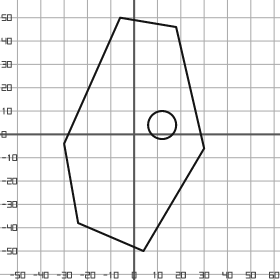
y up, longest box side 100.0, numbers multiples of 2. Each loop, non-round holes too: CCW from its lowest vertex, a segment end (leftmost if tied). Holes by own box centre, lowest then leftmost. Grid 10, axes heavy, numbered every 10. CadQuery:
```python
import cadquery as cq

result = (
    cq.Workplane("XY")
    .moveTo(4.0, -50.0)
    .lineTo(30.0, -6.0)
    .lineTo(18.0, 46.0)
    .lineTo(-6.0, 50.0)
    .lineTo(-30.0, -4.0)
    .lineTo(-24.0, -38.0)
    .close()
    .moveTo(12.0, 4.0)
    .circle(6.0)
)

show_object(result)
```